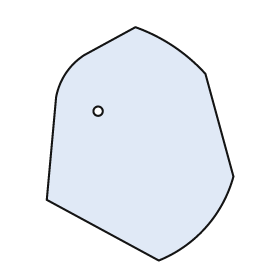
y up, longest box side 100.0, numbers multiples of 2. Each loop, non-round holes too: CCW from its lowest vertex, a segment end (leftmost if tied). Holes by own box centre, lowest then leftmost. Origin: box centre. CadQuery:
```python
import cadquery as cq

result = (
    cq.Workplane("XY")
    .moveTo(8.0, -50.0)
    .threePointArc((28.0, -36.0), (40.0, -14.0))
    .lineTo(28.0, 30.0)
    .threePointArc((14.0, 42.0), (-2.0, 50.0))
    .lineTo(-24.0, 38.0)
    .threePointArc((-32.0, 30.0), (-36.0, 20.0))
    .lineTo(-40.0, -24.0)
    .close()
    .moveTo(-18.0, 14.0)
    .circle(2.0)
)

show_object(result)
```